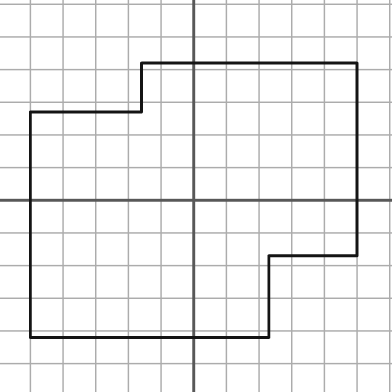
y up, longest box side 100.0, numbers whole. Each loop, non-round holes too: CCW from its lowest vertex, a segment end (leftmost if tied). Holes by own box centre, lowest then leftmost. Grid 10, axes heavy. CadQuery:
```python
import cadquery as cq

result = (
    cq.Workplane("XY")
    .moveTo(-50.0, -42.0)
    .lineTo(23.0, -42.0)
    .lineTo(23.0, -17.0)
    .lineTo(50.0, -17.0)
    .lineTo(50.0, 42.0)
    .lineTo(-16.0, 42.0)
    .lineTo(-16.0, 27.0)
    .lineTo(-50.0, 27.0)
    .close()
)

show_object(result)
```